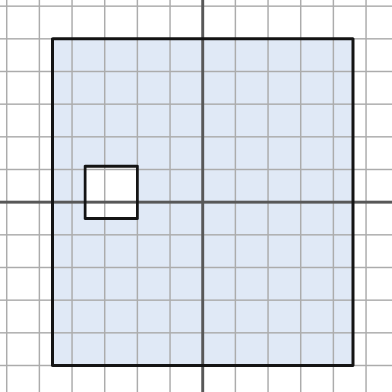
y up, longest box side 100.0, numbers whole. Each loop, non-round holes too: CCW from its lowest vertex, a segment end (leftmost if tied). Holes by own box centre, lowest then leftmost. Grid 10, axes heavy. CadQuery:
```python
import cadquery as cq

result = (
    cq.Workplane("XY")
    .moveTo(-46.0, -50.0)
    .lineTo(46.0, -50.0)
    .lineTo(46.0, 50.0)
    .lineTo(-46.0, 50.0)
    .close()
    .moveTo(-36.0, -5.0)
    .lineTo(-20.0, -5.0)
    .lineTo(-20.0, 11.0)
    .lineTo(-36.0, 11.0)
    .close()
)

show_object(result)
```